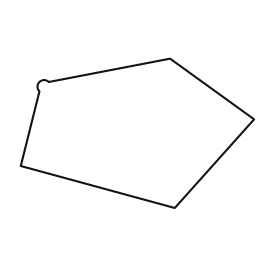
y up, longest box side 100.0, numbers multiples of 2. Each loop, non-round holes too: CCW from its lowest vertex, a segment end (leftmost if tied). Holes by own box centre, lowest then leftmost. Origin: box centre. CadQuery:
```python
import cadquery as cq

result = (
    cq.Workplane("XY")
    .moveTo(16.0, -32.0)
    .lineTo(50.0, 6.0)
    .lineTo(14.0, 32.0)
    .lineTo(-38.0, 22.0)
    .threePointArc((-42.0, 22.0), (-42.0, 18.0))
    .lineTo(-50.0, -14.0)
    .close()
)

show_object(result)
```